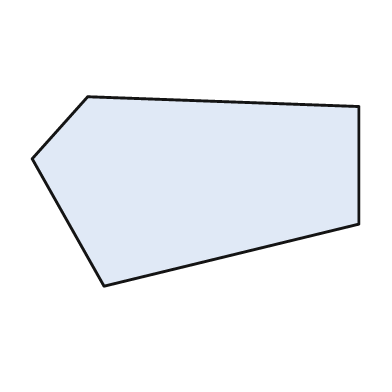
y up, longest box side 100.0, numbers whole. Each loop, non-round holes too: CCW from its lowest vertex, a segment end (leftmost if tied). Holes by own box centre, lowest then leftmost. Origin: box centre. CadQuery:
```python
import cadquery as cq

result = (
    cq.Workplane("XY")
    .moveTo(-28.0, -29.0)
    .lineTo(50.0, -10.0)
    .lineTo(50.0, 26.0)
    .lineTo(-33.0, 29.0)
    .lineTo(-50.0, 10.0)
    .close()
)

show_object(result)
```